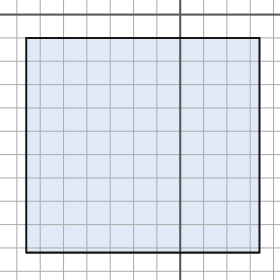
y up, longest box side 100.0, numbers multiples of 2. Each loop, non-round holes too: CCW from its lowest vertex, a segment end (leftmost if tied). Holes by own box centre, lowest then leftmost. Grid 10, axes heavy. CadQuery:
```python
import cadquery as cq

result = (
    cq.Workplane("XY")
    .moveTo(-66.0, -102.0)
    .lineTo(34.0, -102.0)
    .lineTo(34.0, -10.0)
    .lineTo(-66.0, -10.0)
    .close()
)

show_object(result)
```